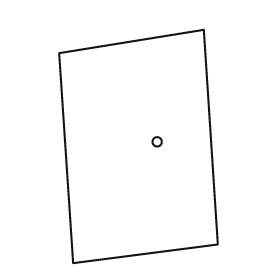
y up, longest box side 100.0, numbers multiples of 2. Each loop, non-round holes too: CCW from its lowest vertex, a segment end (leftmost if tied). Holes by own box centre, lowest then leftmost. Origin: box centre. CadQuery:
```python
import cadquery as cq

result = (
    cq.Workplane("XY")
    .moveTo(-28.0, -50.0)
    .lineTo(34.0, -42.0)
    .lineTo(28.0, 50.0)
    .lineTo(-34.0, 40.0)
    .close()
    .moveTo(8.0, 2.0)
    .circle(2.0)
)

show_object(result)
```